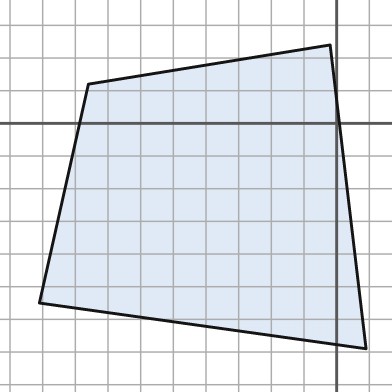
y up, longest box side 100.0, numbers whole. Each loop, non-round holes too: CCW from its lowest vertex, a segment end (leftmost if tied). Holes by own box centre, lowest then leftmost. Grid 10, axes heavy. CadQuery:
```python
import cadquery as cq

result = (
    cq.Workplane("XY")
    .moveTo(9.0, -69.0)
    .lineTo(-2.0, 24.0)
    .lineTo(-76.0, 12.0)
    .lineTo(-91.0, -55.0)
    .close()
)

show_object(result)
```